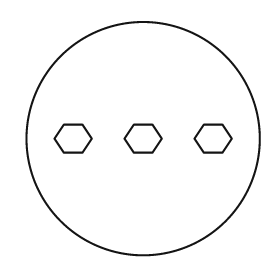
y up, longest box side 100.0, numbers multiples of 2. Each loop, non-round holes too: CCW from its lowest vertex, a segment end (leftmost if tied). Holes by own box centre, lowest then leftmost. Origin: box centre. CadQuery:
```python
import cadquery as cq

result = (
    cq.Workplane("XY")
    .moveTo(0.0, 0.0)
    .circle(50.0)
    .moveTo(-34.0, -6.0)
    .lineTo(-26.0, -6.0)
    .lineTo(-22.0, 0.0)
    .lineTo(-26.0, 6.0)
    .lineTo(-34.0, 6.0)
    .lineTo(-38.0, 0.0)
    .close()
    .moveTo(-4.0, -6.0)
    .lineTo(4.0, -6.0)
    .lineTo(8.0, 0.0)
    .lineTo(4.0, 6.0)
    .lineTo(-4.0, 6.0)
    .lineTo(-8.0, 0.0)
    .close()
    .moveTo(26.0, -6.0)
    .lineTo(34.0, -6.0)
    .lineTo(38.0, 0.0)
    .lineTo(34.0, 6.0)
    .lineTo(26.0, 6.0)
    .lineTo(22.0, 0.0)
    .close()
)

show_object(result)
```